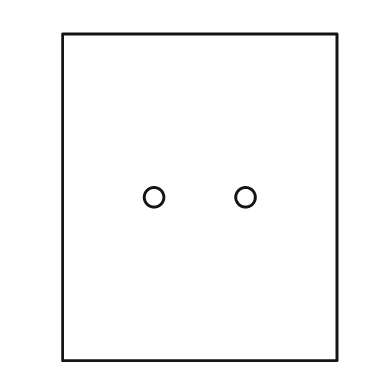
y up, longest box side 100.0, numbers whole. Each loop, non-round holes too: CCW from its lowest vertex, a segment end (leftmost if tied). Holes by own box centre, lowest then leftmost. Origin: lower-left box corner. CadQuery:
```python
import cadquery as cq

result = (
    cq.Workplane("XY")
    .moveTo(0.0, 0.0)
    .lineTo(84.0, 0.0)
    .lineTo(84.0, 100.0)
    .lineTo(0.0, 100.0)
    .close()
    .moveTo(28.0, 50.0)
    .circle(3.0)
    .moveTo(56.0, 50.0)
    .circle(3.0)
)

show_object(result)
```